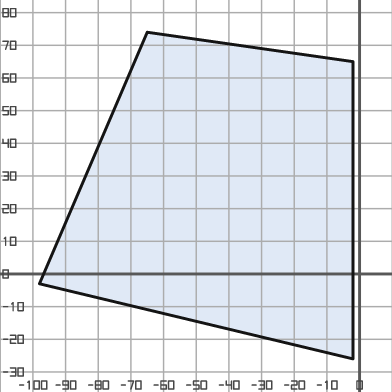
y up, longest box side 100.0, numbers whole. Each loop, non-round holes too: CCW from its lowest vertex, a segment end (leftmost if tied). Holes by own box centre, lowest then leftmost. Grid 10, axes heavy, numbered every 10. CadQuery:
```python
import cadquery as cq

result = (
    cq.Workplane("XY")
    .moveTo(-2.0, -26.0)
    .lineTo(-2.0, 65.0)
    .lineTo(-65.0, 74.0)
    .lineTo(-98.0, -3.0)
    .close()
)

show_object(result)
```